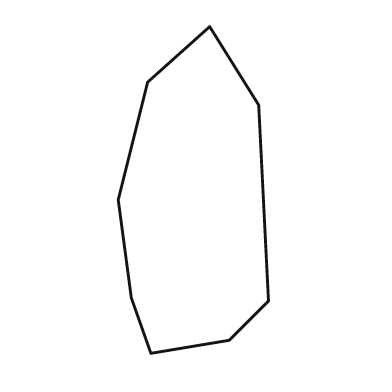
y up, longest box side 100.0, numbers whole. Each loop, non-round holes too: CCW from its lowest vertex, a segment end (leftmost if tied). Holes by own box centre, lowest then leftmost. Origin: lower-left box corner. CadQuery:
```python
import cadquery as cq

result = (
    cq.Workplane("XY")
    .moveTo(10.0, 0.0)
    .lineTo(34.0, 4.0)
    .lineTo(46.0, 16.0)
    .lineTo(43.0, 76.0)
    .lineTo(28.0, 100.0)
    .lineTo(9.0, 83.0)
    .lineTo(0.0, 47.0)
    .lineTo(4.0, 17.0)
    .close()
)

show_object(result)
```